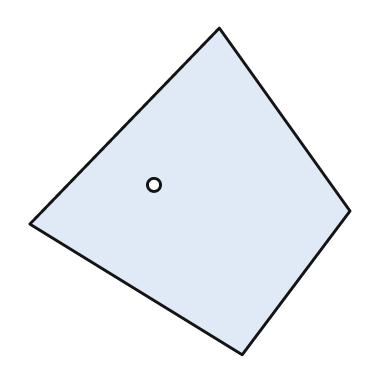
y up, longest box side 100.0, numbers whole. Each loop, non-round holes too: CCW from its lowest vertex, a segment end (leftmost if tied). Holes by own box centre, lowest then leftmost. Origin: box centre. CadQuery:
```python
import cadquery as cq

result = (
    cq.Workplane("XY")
    .moveTo(16.0, -50.0)
    .lineTo(49.0, -6.0)
    .lineTo(9.0, 50.0)
    .lineTo(-49.0, -10.0)
    .close()
    .moveTo(-11.0, 2.0)
    .circle(2.0)
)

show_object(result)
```